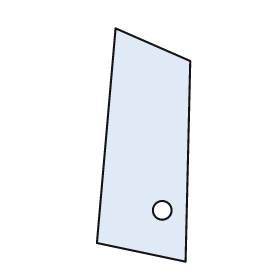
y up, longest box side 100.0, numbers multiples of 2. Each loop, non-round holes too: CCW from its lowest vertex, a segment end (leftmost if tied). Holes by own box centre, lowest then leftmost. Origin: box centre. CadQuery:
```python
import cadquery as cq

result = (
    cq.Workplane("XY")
    .moveTo(18.0, -50.0)
    .lineTo(20.0, 36.0)
    .lineTo(-12.0, 50.0)
    .lineTo(-20.0, -42.0)
    .close()
    .moveTo(8.0, -28.0)
    .circle(4.0)
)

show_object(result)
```